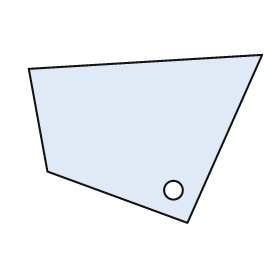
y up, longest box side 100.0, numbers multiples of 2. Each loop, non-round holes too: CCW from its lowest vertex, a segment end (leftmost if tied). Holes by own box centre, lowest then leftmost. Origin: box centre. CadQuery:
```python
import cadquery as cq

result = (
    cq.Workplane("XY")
    .moveTo(18.0, -36.0)
    .lineTo(50.0, 36.0)
    .lineTo(-50.0, 30.0)
    .lineTo(-42.0, -14.0)
    .close()
    .moveTo(12.0, -22.0)
    .circle(4.0)
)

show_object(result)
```